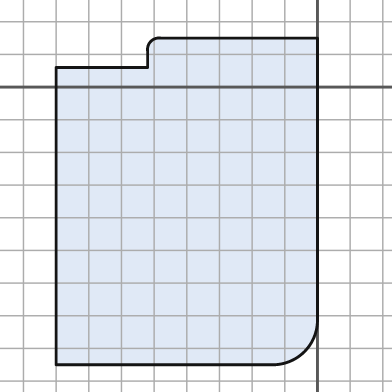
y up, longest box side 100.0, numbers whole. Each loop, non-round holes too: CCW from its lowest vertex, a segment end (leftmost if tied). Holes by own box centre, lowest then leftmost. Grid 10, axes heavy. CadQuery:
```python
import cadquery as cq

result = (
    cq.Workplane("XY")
    .moveTo(-80.0, -85.0)
    .lineTo(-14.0, -85.0)
    .threePointArc((-4.0, -81.0), (0.0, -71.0))
    .lineTo(0.0, 15.0)
    .lineTo(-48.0, 15.0)
    .threePointArc((-51.0, 14.0), (-52.0, 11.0))
    .lineTo(-52.0, 6.0)
    .lineTo(-80.0, 6.0)
    .close()
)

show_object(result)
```